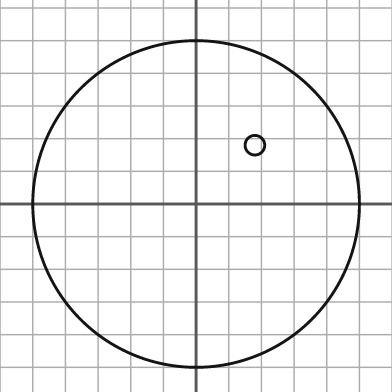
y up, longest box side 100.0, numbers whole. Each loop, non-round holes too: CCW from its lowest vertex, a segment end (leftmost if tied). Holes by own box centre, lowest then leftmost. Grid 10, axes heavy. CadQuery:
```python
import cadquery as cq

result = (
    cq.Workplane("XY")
    .moveTo(0.0, 0.0)
    .circle(50.0)
    .moveTo(18.0, 18.0)
    .circle(3.0)
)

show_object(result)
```